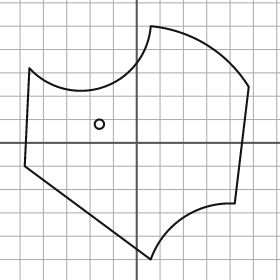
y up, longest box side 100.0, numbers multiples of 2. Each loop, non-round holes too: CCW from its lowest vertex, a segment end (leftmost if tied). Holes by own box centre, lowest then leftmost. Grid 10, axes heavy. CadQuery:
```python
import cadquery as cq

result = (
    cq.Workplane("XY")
    .moveTo(6.0, -50.0)
    .threePointArc((20.0, -32.0), (42.0, -26.0))
    .lineTo(48.0, 24.0)
    .threePointArc((30.0, 42.0), (6.0, 50.0))
    .threePointArc((-14.0, 24.0), (-46.0, 32.0))
    .lineTo(-48.0, -10.0)
    .close()
    .moveTo(-16.0, 8.0)
    .circle(2.0)
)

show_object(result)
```